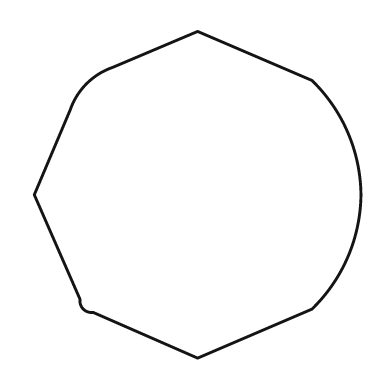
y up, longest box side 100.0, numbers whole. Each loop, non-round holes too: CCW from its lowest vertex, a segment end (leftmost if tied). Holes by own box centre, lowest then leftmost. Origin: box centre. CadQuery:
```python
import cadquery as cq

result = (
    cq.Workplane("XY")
    .moveTo(0.0, -50.0)
    .lineTo(35.0, -35.0)
    .threePointArc((46.0, -19.0), (50.0, 0.0))
    .threePointArc((46.0, 19.0), (35.0, 35.0))
    .lineTo(0.0, 50.0)
    .lineTo(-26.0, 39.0)
    .threePointArc((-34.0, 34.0), (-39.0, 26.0))
    .lineTo(-50.0, 0.0)
    .lineTo(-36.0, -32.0)
    .threePointArc((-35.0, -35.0), (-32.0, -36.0))
    .close()
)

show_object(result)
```